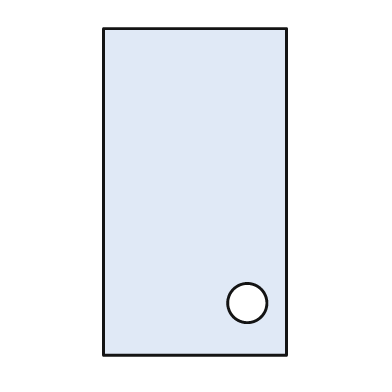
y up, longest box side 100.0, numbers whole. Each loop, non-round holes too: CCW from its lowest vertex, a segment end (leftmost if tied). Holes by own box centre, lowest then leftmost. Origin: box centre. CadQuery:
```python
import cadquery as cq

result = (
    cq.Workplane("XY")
    .moveTo(-28.0, -50.0)
    .lineTo(28.0, -50.0)
    .lineTo(28.0, 50.0)
    .lineTo(-28.0, 50.0)
    .close()
    .moveTo(16.0, -34.0)
    .circle(6.0)
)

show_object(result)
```